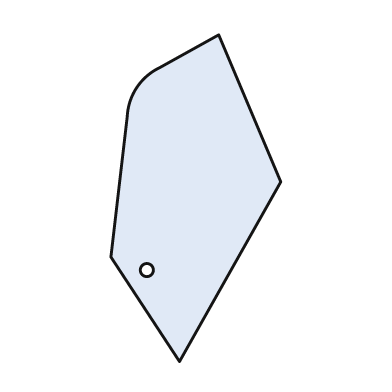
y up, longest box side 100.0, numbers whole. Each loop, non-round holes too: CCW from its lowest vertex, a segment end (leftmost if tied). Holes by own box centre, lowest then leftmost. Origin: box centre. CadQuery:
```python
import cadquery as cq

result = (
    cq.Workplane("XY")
    .moveTo(-5.0, -50.0)
    .lineTo(26.0, 5.0)
    .lineTo(7.0, 50.0)
    .lineTo(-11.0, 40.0)
    .threePointArc((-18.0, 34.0), (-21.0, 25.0))
    .lineTo(-26.0, -18.0)
    .close()
    .moveTo(-15.0, -22.0)
    .circle(2.0)
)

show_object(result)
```